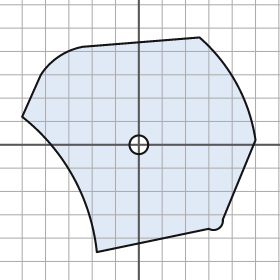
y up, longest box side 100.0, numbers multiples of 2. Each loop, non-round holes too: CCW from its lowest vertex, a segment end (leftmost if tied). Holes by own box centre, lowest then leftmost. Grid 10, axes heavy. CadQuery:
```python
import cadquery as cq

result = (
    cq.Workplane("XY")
    .moveTo(-18.0, -46.0)
    .lineTo(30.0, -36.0)
    .threePointArc((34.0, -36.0), (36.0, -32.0))
    .lineTo(50.0, 2.0)
    .threePointArc((42.0, 26.0), (26.0, 46.0))
    .lineTo(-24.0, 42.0)
    .threePointArc((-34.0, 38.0), (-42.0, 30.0))
    .lineTo(-50.0, 12.0)
    .threePointArc((-28.0, -14.0), (-18.0, -46.0))
    .close()
    .moveTo(0.0, 0.0)
    .circle(4.0)
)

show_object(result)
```